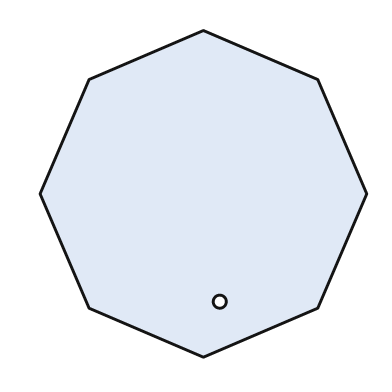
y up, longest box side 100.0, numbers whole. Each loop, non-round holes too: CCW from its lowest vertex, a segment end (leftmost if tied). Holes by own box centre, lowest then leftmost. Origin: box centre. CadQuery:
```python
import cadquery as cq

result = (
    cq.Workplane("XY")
    .moveTo(0.0, -50.0)
    .lineTo(35.0, -35.0)
    .lineTo(50.0, 0.0)
    .lineTo(35.0, 35.0)
    .lineTo(0.0, 50.0)
    .lineTo(-35.0, 35.0)
    .lineTo(-50.0, 0.0)
    .lineTo(-35.0, -35.0)
    .close()
    .moveTo(5.0, -33.0)
    .circle(2.0)
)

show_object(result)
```